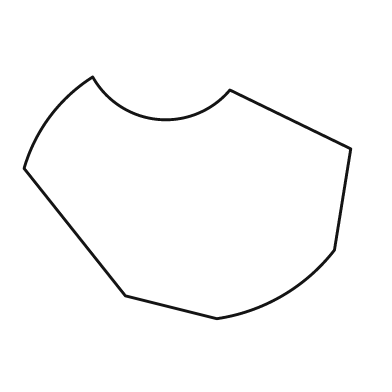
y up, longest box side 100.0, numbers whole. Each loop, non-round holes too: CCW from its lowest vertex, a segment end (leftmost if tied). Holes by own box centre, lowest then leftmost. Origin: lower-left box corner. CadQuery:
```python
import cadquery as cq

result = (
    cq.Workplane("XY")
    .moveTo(59.0, 0.0)
    .threePointArc((79.0, 7.0), (95.0, 21.0))
    .lineTo(100.0, 52.0)
    .lineTo(63.0, 70.0)
    .threePointArc((41.0, 61.0), (21.0, 74.0))
    .threePointArc((8.0, 62.0), (0.0, 46.0))
    .lineTo(31.0, 7.0)
    .close()
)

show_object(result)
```